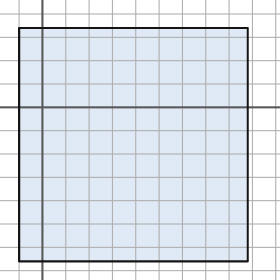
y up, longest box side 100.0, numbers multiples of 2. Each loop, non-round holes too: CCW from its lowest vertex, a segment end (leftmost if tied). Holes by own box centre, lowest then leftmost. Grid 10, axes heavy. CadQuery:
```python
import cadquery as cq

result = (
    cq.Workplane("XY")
    .moveTo(-10.0, -66.0)
    .lineTo(88.0, -66.0)
    .lineTo(88.0, 34.0)
    .lineTo(-10.0, 34.0)
    .close()
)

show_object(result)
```